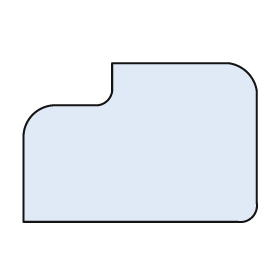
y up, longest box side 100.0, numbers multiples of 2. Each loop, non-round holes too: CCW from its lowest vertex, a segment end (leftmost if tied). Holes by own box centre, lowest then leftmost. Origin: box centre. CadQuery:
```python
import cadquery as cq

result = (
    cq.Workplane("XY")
    .moveTo(-50.0, -34.0)
    .lineTo(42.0, -34.0)
    .threePointArc((48.0, -32.0), (50.0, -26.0))
    .lineTo(50.0, 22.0)
    .threePointArc((46.0, 30.0), (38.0, 34.0))
    .lineTo(-12.0, 34.0)
    .lineTo(-12.0, 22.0)
    .threePointArc((-14.0, 18.0), (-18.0, 16.0))
    .lineTo(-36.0, 16.0)
    .threePointArc((-46.0, 12.0), (-50.0, 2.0))
    .close()
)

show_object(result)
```